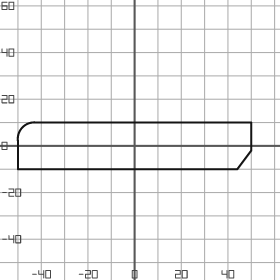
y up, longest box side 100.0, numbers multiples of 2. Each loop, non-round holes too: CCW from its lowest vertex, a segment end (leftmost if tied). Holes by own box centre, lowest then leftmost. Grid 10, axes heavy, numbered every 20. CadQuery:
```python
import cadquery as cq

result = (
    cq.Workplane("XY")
    .moveTo(-50.0, -10.0)
    .lineTo(44.0, -10.0)
    .lineTo(50.0, -2.0)
    .lineTo(50.0, 10.0)
    .lineTo(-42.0, 10.0)
    .threePointArc((-48.0, 8.0), (-50.0, 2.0))
    .close()
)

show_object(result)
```